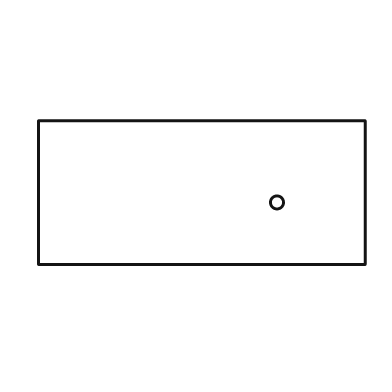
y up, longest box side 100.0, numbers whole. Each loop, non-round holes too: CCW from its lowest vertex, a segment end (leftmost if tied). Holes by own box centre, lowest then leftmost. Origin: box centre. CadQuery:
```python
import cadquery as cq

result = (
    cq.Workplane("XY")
    .moveTo(-50.0, -22.0)
    .lineTo(50.0, -22.0)
    .lineTo(50.0, 22.0)
    .lineTo(-50.0, 22.0)
    .close()
    .moveTo(23.0, -3.0)
    .circle(2.0)
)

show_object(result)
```